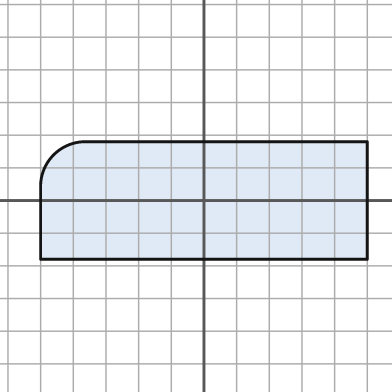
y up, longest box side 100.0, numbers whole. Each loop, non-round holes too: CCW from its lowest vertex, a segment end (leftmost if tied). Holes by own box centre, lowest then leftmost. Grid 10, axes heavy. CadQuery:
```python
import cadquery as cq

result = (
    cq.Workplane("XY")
    .moveTo(-50.0, -18.0)
    .lineTo(50.0, -18.0)
    .lineTo(50.0, 18.0)
    .lineTo(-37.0, 18.0)
    .threePointArc((-46.0, 14.0), (-50.0, 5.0))
    .close()
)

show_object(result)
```